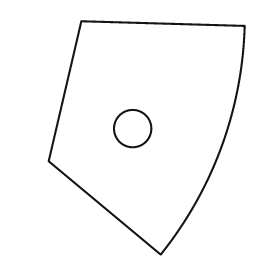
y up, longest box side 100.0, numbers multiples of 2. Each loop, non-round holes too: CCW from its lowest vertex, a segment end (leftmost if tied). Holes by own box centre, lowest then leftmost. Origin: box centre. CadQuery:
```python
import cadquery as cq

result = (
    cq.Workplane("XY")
    .moveTo(6.0, -50.0)
    .threePointArc((32.0, -4.0), (42.0, 48.0))
    .lineTo(-28.0, 50.0)
    .lineTo(-42.0, -10.0)
    .close()
    .moveTo(-6.0, 4.0)
    .circle(8.0)
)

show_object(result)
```